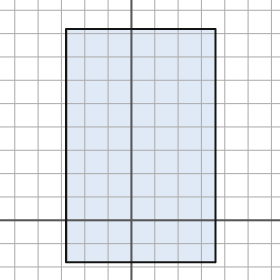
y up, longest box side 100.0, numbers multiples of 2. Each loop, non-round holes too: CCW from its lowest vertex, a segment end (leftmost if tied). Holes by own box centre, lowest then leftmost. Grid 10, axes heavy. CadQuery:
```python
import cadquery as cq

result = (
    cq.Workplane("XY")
    .moveTo(-28.0, -18.0)
    .lineTo(36.0, -18.0)
    .lineTo(36.0, 82.0)
    .lineTo(-28.0, 82.0)
    .close()
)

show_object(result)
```